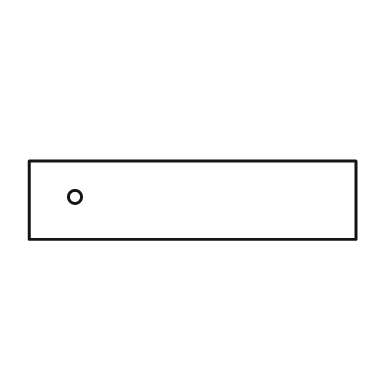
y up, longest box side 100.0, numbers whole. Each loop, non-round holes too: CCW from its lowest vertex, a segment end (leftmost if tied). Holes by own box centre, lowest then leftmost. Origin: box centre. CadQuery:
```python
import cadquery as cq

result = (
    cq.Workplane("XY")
    .moveTo(-50.0, -12.0)
    .lineTo(50.0, -12.0)
    .lineTo(50.0, 12.0)
    .lineTo(-50.0, 12.0)
    .close()
    .moveTo(-36.0, 1.0)
    .circle(2.0)
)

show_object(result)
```